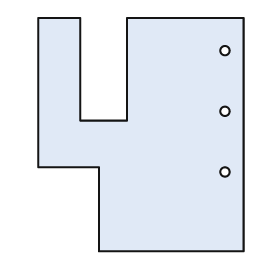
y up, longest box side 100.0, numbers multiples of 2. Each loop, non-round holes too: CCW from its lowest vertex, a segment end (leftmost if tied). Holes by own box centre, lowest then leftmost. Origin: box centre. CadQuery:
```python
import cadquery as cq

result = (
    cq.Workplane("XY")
    .moveTo(-18.0, -50.0)
    .lineTo(44.0, -50.0)
    .lineTo(44.0, 50.0)
    .lineTo(-6.0, 50.0)
    .lineTo(-6.0, 6.0)
    .lineTo(-26.0, 6.0)
    .lineTo(-26.0, 50.0)
    .lineTo(-44.0, 50.0)
    .lineTo(-44.0, -14.0)
    .lineTo(-18.0, -14.0)
    .close()
    .moveTo(36.0, -16.0)
    .circle(2.0)
    .moveTo(36.0, 10.0)
    .circle(2.0)
    .moveTo(36.0, 36.0)
    .circle(2.0)
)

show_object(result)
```